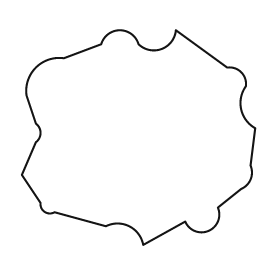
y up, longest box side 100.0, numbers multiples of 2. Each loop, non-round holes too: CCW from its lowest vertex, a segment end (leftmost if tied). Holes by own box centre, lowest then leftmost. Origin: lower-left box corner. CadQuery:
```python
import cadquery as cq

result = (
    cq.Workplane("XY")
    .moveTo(52.0, 0.0)
    .lineTo(70.0, 10.0)
    .threePointArc((80.0, 6.0), (84.0, 16.0))
    .lineTo(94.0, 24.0)
    .threePointArc((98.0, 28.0), (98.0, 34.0))
    .lineTo(100.0, 50.0)
    .threePointArc((94.0, 58.0), (96.0, 68.0))
    .threePointArc((94.0, 74.0), (88.0, 76.0))
    .lineTo(66.0, 92.0)
    .threePointArc((60.0, 84.0), (50.0, 86.0))
    .threePointArc((42.0, 92.0), (34.0, 86.0))
    .lineTo(18.0, 80.0)
    .threePointArc((6.0, 76.0), (2.0, 64.0))
    .lineTo(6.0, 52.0)
    .threePointArc((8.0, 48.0), (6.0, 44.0))
    .lineTo(0.0, 30.0)
    .lineTo(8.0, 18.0)
    .threePointArc((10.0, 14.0), (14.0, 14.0))
    .lineTo(36.0, 8.0)
    .threePointArc((46.0, 8.0), (52.0, 0.0))
    .close()
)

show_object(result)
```